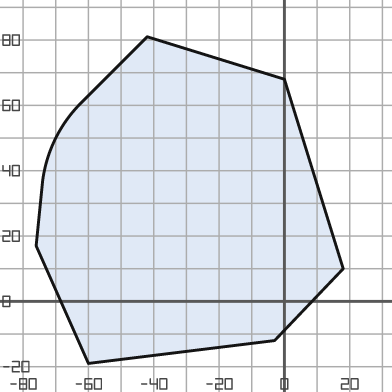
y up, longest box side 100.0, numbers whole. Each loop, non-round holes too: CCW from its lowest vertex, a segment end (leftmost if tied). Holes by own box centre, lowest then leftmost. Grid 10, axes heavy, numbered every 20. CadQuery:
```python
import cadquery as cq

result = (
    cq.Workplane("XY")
    .moveTo(-60.0, -19.0)
    .lineTo(-3.0, -12.0)
    .lineTo(18.0, 10.0)
    .lineTo(0.0, 68.0)
    .lineTo(-42.0, 81.0)
    .lineTo(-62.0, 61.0)
    .threePointArc((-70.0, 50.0), (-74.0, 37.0))
    .lineTo(-76.0, 17.0)
    .close()
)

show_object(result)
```